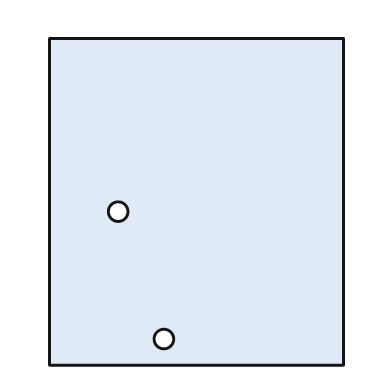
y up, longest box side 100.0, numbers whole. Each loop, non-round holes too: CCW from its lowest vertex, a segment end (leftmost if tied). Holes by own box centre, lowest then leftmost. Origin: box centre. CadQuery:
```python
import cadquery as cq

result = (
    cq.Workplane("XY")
    .moveTo(-45.0, -50.0)
    .lineTo(45.0, -50.0)
    .lineTo(45.0, 50.0)
    .lineTo(-45.0, 50.0)
    .close()
    .moveTo(-10.0, -42.0)
    .circle(3.0)
    .moveTo(-24.0, -3.0)
    .circle(3.0)
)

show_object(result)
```